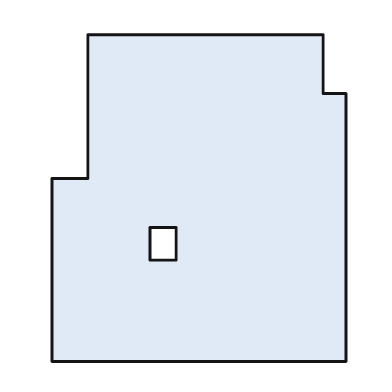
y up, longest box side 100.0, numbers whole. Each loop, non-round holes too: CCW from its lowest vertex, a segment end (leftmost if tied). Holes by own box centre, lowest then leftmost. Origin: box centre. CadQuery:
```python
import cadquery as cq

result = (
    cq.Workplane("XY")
    .moveTo(-45.0, -50.0)
    .lineTo(45.0, -50.0)
    .lineTo(45.0, 32.0)
    .lineTo(38.0, 32.0)
    .lineTo(38.0, 50.0)
    .lineTo(-34.0, 50.0)
    .lineTo(-34.0, 6.0)
    .lineTo(-45.0, 6.0)
    .close()
    .moveTo(-15.0, -19.0)
    .lineTo(-7.0, -19.0)
    .lineTo(-7.0, -9.0)
    .lineTo(-15.0, -9.0)
    .close()
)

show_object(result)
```